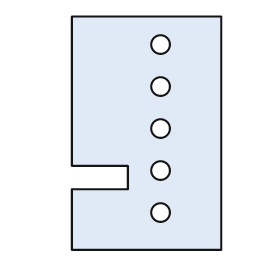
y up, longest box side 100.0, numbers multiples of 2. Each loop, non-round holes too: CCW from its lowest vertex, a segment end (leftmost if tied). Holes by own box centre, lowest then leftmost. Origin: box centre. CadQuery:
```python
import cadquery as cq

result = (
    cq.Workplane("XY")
    .moveTo(-32.0, -50.0)
    .lineTo(32.0, -50.0)
    .lineTo(32.0, 50.0)
    .lineTo(-32.0, 50.0)
    .lineTo(-32.0, -14.0)
    .lineTo(-8.0, -14.0)
    .lineTo(-8.0, -24.0)
    .lineTo(-32.0, -24.0)
    .close()
    .moveTo(6.0, -34.0)
    .circle(4.0)
    .moveTo(6.0, -16.0)
    .circle(4.0)
    .moveTo(6.0, 2.0)
    .circle(4.0)
    .moveTo(6.0, 20.0)
    .circle(4.0)
    .moveTo(6.0, 38.0)
    .circle(4.0)
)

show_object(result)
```